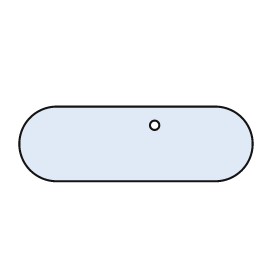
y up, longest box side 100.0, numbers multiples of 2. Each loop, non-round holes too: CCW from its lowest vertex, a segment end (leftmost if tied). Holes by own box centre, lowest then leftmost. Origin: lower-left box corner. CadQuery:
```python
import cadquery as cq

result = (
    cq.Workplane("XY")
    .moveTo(16.0, 0.0)
    .lineTo(84.0, 0.0)
    .threePointArc((100.0, 16.0), (84.0, 32.0))
    .lineTo(16.0, 32.0)
    .threePointArc((0.0, 16.0), (16.0, 0.0))
    .close()
    .moveTo(58.0, 24.0)
    .circle(2.0)
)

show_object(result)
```